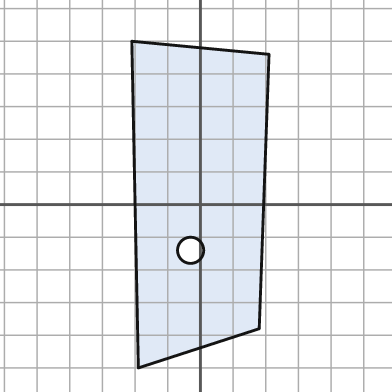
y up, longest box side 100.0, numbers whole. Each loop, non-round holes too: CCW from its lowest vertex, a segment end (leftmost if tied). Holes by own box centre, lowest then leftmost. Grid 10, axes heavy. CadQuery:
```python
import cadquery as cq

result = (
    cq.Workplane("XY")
    .moveTo(-19.0, -50.0)
    .lineTo(18.0, -38.0)
    .lineTo(21.0, 46.0)
    .lineTo(-21.0, 50.0)
    .close()
    .moveTo(-3.0, -14.0)
    .circle(4.0)
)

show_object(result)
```